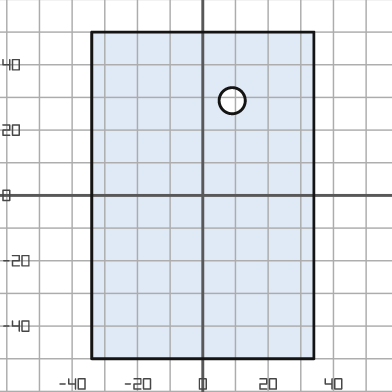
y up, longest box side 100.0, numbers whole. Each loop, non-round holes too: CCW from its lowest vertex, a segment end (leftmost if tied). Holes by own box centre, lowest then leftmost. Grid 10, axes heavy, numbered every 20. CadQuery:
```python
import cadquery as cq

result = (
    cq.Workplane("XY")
    .moveTo(-34.0, -50.0)
    .lineTo(34.0, -50.0)
    .lineTo(34.0, 50.0)
    .lineTo(-34.0, 50.0)
    .close()
    .moveTo(9.0, 29.0)
    .circle(4.0)
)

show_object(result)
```